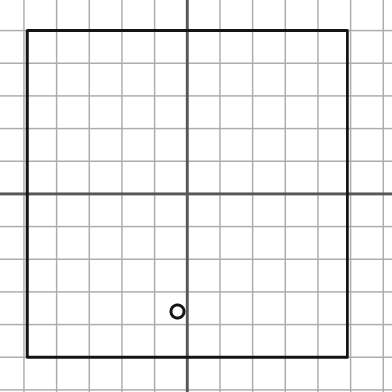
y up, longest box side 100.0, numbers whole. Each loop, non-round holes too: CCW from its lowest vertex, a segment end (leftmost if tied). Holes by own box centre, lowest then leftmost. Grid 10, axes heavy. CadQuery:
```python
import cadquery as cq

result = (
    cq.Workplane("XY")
    .moveTo(-49.0, -50.0)
    .lineTo(49.0, -50.0)
    .lineTo(49.0, 50.0)
    .lineTo(-49.0, 50.0)
    .close()
    .moveTo(-3.0, -36.0)
    .circle(2.0)
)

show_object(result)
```